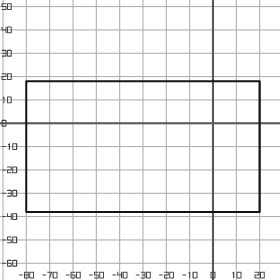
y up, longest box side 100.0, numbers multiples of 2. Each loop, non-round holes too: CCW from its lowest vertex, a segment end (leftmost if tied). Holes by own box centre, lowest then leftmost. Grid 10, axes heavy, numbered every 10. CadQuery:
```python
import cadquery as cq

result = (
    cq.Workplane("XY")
    .moveTo(-80.0, -38.0)
    .lineTo(20.0, -38.0)
    .lineTo(20.0, 18.0)
    .lineTo(-80.0, 18.0)
    .close()
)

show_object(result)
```